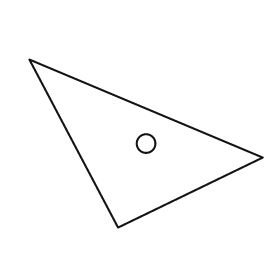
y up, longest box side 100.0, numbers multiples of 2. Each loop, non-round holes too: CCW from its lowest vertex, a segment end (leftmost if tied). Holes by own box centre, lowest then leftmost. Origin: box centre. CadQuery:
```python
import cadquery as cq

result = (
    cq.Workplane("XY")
    .moveTo(-12.0, -36.0)
    .lineTo(50.0, -6.0)
    .lineTo(-50.0, 36.0)
    .close()
    .moveTo(0.0, 0.0)
    .circle(4.0)
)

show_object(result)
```